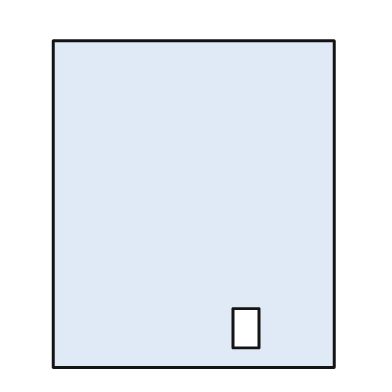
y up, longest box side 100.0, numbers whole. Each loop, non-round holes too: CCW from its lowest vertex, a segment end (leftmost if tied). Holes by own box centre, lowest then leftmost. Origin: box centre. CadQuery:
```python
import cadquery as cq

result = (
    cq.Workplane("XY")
    .moveTo(-43.0, -50.0)
    .lineTo(43.0, -50.0)
    .lineTo(43.0, 50.0)
    .lineTo(-43.0, 50.0)
    .close()
    .moveTo(12.0, -44.0)
    .lineTo(20.0, -44.0)
    .lineTo(20.0, -32.0)
    .lineTo(12.0, -32.0)
    .close()
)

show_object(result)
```